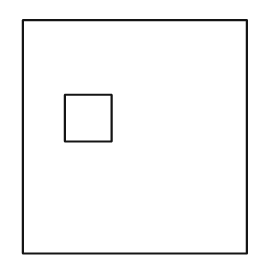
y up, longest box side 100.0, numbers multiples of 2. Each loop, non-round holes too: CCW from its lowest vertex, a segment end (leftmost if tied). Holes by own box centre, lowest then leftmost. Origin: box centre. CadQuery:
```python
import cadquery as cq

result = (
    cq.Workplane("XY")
    .moveTo(-48.0, -50.0)
    .lineTo(48.0, -50.0)
    .lineTo(48.0, 50.0)
    .lineTo(-48.0, 50.0)
    .close()
    .moveTo(-30.0, -2.0)
    .lineTo(-10.0, -2.0)
    .lineTo(-10.0, 18.0)
    .lineTo(-30.0, 18.0)
    .close()
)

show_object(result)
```